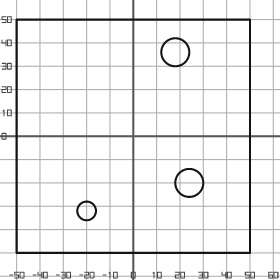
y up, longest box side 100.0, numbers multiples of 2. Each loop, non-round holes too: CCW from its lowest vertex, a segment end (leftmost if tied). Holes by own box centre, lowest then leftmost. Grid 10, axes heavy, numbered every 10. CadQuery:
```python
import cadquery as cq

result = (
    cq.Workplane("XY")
    .moveTo(-50.0, -50.0)
    .lineTo(50.0, -50.0)
    .lineTo(50.0, 50.0)
    .lineTo(-50.0, 50.0)
    .close()
    .moveTo(-20.0, -32.0)
    .circle(4.0)
    .moveTo(24.0, -20.0)
    .circle(6.0)
    .moveTo(18.0, 36.0)
    .circle(6.0)
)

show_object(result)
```